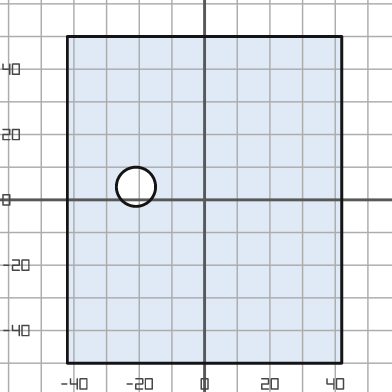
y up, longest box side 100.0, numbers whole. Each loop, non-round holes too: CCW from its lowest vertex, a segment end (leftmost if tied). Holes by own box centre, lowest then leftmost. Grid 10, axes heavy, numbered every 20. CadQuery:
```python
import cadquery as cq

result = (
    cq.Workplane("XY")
    .moveTo(-42.0, -50.0)
    .lineTo(42.0, -50.0)
    .lineTo(42.0, 50.0)
    .lineTo(-42.0, 50.0)
    .close()
    .moveTo(-21.0, 4.0)
    .circle(6.0)
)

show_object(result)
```